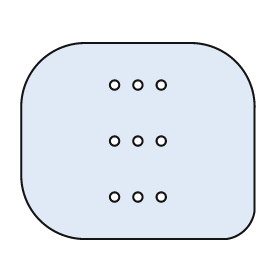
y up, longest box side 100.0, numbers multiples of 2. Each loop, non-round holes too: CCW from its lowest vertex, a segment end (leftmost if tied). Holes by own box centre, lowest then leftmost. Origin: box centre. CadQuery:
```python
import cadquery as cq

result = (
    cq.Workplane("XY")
    .moveTo(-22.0, -42.0)
    .lineTo(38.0, -42.0)
    .threePointArc((46.0, -38.0), (50.0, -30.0))
    .lineTo(50.0, 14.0)
    .threePointArc((42.0, 34.0), (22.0, 42.0))
    .lineTo(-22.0, 42.0)
    .threePointArc((-42.0, 34.0), (-50.0, 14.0))
    .lineTo(-50.0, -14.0)
    .threePointArc((-42.0, -34.0), (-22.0, -42.0))
    .close()
    .moveTo(-10.0, -24.0)
    .circle(2.0)
    .moveTo(0.0, -24.0)
    .circle(2.0)
    .moveTo(10.0, -24.0)
    .circle(2.0)
    .moveTo(-10.0, 0.0)
    .circle(2.0)
    .moveTo(0.0, 0.0)
    .circle(2.0)
    .moveTo(10.0, 0.0)
    .circle(2.0)
    .moveTo(-10.0, 24.0)
    .circle(2.0)
    .moveTo(0.0, 24.0)
    .circle(2.0)
    .moveTo(10.0, 24.0)
    .circle(2.0)
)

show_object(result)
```